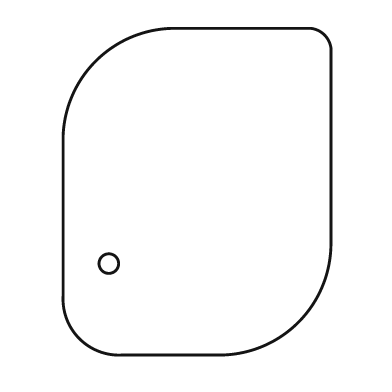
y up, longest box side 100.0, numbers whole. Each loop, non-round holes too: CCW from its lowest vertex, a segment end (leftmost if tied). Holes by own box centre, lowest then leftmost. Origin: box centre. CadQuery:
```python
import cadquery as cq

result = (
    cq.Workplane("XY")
    .moveTo(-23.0, -50.0)
    .lineTo(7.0, -50.0)
    .threePointArc((31.0, -40.0), (41.0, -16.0))
    .lineTo(41.0, 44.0)
    .threePointArc((39.0, 48.0), (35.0, 50.0))
    .lineTo(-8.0, 50.0)
    .threePointArc((-31.0, 40.0), (-41.0, 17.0))
    .lineTo(-41.0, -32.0)
    .threePointArc((-36.0, -45.0), (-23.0, -50.0))
    .close()
    .moveTo(-27.0, -22.0)
    .circle(3.0)
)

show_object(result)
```